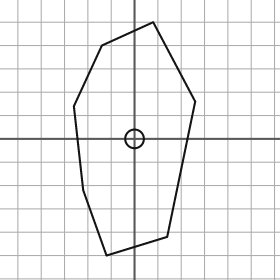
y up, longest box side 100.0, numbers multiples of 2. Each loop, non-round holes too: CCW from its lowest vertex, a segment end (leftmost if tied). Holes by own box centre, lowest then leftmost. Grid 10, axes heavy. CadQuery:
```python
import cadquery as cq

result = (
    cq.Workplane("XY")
    .moveTo(-12.0, -50.0)
    .lineTo(14.0, -42.0)
    .lineTo(26.0, 16.0)
    .lineTo(8.0, 50.0)
    .lineTo(-14.0, 40.0)
    .lineTo(-26.0, 14.0)
    .lineTo(-22.0, -22.0)
    .close()
    .moveTo(0.0, 0.0)
    .circle(4.0)
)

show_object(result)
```